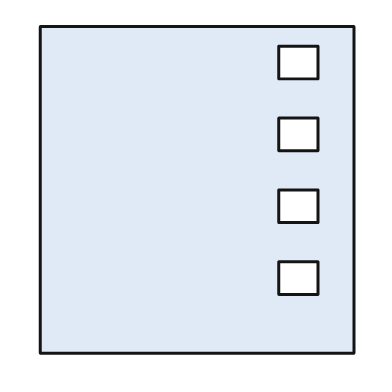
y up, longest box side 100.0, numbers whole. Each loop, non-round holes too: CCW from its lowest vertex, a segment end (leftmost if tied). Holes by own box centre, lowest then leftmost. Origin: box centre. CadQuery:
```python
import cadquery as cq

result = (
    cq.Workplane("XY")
    .moveTo(-48.0, -50.0)
    .lineTo(48.0, -50.0)
    .lineTo(48.0, 50.0)
    .lineTo(-48.0, 50.0)
    .close()
    .moveTo(25.0, -32.0)
    .lineTo(37.0, -32.0)
    .lineTo(37.0, -22.0)
    .lineTo(25.0, -22.0)
    .close()
    .moveTo(25.0, -10.0)
    .lineTo(37.0, -10.0)
    .lineTo(37.0, 0.0)
    .lineTo(25.0, 0.0)
    .close()
    .moveTo(25.0, 12.0)
    .lineTo(37.0, 12.0)
    .lineTo(37.0, 22.0)
    .lineTo(25.0, 22.0)
    .close()
    .moveTo(25.0, 34.0)
    .lineTo(37.0, 34.0)
    .lineTo(37.0, 44.0)
    .lineTo(25.0, 44.0)
    .close()
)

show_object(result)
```